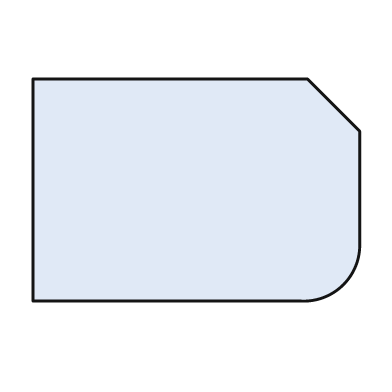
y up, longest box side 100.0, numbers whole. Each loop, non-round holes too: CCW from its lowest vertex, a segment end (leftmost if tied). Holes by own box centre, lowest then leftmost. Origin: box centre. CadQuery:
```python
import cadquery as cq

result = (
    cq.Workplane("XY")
    .moveTo(-50.0, -34.0)
    .lineTo(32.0, -34.0)
    .threePointArc((45.0, -29.0), (50.0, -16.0))
    .lineTo(50.0, 18.0)
    .lineTo(34.0, 34.0)
    .lineTo(-50.0, 34.0)
    .close()
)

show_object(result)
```